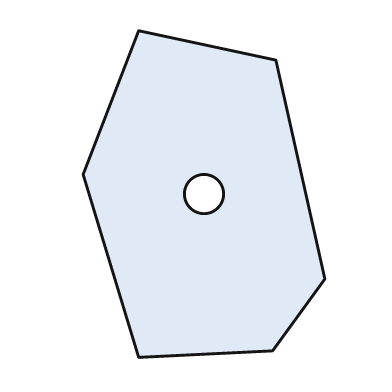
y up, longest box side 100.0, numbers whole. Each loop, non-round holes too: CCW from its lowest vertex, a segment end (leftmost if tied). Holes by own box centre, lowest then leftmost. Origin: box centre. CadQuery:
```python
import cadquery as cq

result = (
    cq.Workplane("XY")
    .moveTo(-20.0, -50.0)
    .lineTo(21.0, -48.0)
    .lineTo(37.0, -26.0)
    .lineTo(22.0, 41.0)
    .lineTo(-20.0, 50.0)
    .lineTo(-37.0, 6.0)
    .close()
    .moveTo(0.0, 0.0)
    .circle(6.0)
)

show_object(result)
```